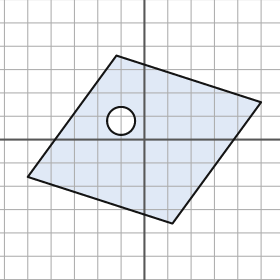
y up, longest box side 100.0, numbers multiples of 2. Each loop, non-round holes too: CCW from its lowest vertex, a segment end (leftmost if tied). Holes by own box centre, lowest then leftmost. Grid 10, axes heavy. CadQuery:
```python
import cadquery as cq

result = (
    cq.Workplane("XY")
    .moveTo(12.0, -36.0)
    .lineTo(50.0, 16.0)
    .lineTo(-12.0, 36.0)
    .lineTo(-50.0, -16.0)
    .close()
    .moveTo(-10.0, 8.0)
    .circle(6.0)
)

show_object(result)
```